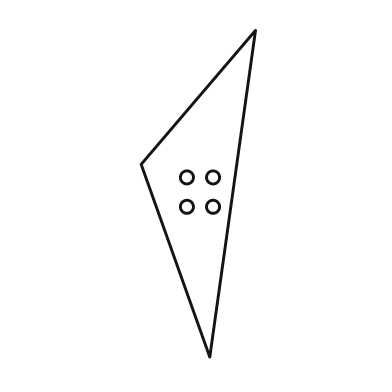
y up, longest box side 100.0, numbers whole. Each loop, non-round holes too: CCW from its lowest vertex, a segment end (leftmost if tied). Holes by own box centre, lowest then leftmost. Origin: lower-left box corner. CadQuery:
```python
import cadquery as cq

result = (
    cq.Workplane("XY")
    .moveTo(21.0, 0.0)
    .lineTo(35.0, 100.0)
    .lineTo(0.0, 59.0)
    .close()
    .moveTo(14.0, 46.0)
    .circle(2.0)
    .moveTo(22.0, 46.0)
    .circle(2.0)
    .moveTo(14.0, 55.0)
    .circle(2.0)
    .moveTo(22.0, 55.0)
    .circle(2.0)
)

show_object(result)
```